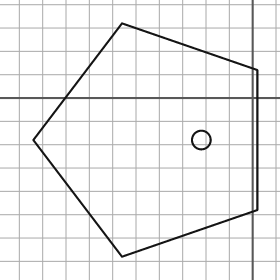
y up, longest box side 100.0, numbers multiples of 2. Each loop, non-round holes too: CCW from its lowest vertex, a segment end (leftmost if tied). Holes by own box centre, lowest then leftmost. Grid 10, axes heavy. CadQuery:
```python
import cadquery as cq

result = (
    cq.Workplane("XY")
    .moveTo(-56.0, -68.0)
    .lineTo(2.0, -48.0)
    .lineTo(2.0, 12.0)
    .lineTo(-56.0, 32.0)
    .lineTo(-94.0, -18.0)
    .close()
    .moveTo(-22.0, -18.0)
    .circle(4.0)
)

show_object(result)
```